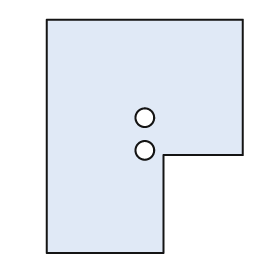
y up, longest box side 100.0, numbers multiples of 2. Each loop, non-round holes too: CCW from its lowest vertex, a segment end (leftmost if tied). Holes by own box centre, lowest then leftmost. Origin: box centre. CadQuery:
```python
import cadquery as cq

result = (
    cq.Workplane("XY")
    .moveTo(-42.0, -50.0)
    .lineTo(8.0, -50.0)
    .lineTo(8.0, -8.0)
    .lineTo(42.0, -8.0)
    .lineTo(42.0, 50.0)
    .lineTo(-42.0, 50.0)
    .close()
    .moveTo(0.0, -6.0)
    .circle(4.0)
    .moveTo(0.0, 8.0)
    .circle(4.0)
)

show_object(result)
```